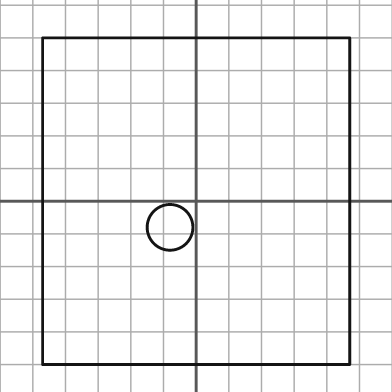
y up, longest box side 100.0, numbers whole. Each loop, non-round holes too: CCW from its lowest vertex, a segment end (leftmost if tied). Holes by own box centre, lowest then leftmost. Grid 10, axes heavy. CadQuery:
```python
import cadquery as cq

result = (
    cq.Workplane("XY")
    .moveTo(-47.0, -50.0)
    .lineTo(47.0, -50.0)
    .lineTo(47.0, 50.0)
    .lineTo(-47.0, 50.0)
    .close()
    .moveTo(-8.0, -8.0)
    .circle(7.0)
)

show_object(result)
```